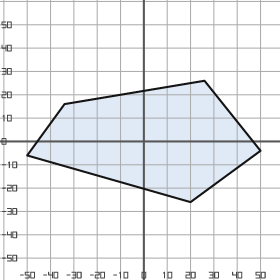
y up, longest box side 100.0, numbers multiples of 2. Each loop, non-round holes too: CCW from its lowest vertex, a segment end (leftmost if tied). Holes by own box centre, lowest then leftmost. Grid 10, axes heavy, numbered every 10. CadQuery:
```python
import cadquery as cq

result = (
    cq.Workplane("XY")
    .moveTo(20.0, -26.0)
    .lineTo(50.0, -4.0)
    .lineTo(26.0, 26.0)
    .lineTo(-34.0, 16.0)
    .lineTo(-50.0, -6.0)
    .close()
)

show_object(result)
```